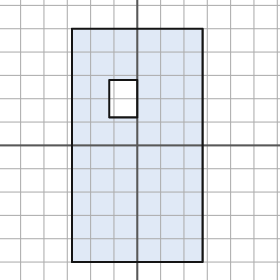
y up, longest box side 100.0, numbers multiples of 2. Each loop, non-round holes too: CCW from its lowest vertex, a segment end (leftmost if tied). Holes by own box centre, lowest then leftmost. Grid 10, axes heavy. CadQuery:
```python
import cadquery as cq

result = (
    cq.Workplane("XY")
    .moveTo(-28.0, -50.0)
    .lineTo(28.0, -50.0)
    .lineTo(28.0, 50.0)
    .lineTo(-28.0, 50.0)
    .close()
    .moveTo(-12.0, 12.0)
    .lineTo(0.0, 12.0)
    .lineTo(0.0, 28.0)
    .lineTo(-12.0, 28.0)
    .close()
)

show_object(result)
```